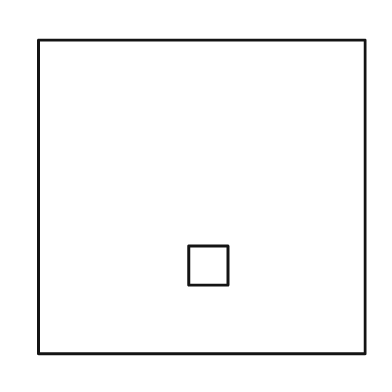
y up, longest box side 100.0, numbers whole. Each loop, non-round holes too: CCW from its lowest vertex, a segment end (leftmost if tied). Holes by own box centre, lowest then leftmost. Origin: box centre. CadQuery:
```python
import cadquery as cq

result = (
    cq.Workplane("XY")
    .moveTo(-50.0, -48.0)
    .lineTo(50.0, -48.0)
    .lineTo(50.0, 48.0)
    .lineTo(-50.0, 48.0)
    .close()
    .moveTo(-4.0, -27.0)
    .lineTo(8.0, -27.0)
    .lineTo(8.0, -15.0)
    .lineTo(-4.0, -15.0)
    .close()
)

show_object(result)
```